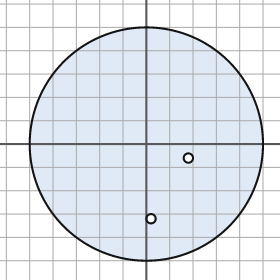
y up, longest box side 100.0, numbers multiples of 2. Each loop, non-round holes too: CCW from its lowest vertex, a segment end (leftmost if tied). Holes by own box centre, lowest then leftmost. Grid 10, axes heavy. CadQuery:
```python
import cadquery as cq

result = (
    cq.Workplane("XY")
    .moveTo(0.0, 0.0)
    .circle(50.0)
    .moveTo(2.0, -32.0)
    .circle(2.0)
    .moveTo(18.0, -6.0)
    .circle(2.0)
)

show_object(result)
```